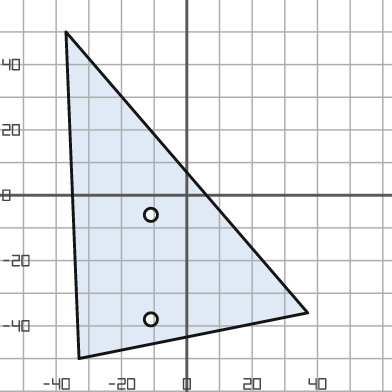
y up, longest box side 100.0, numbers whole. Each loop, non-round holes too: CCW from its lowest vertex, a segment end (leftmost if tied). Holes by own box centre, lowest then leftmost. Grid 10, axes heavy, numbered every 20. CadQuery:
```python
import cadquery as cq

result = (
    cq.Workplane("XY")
    .moveTo(-33.0, -50.0)
    .lineTo(37.0, -36.0)
    .lineTo(-37.0, 50.0)
    .close()
    .moveTo(-11.0, -38.0)
    .circle(2.0)
    .moveTo(-11.0, -6.0)
    .circle(2.0)
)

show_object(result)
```